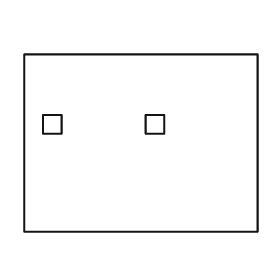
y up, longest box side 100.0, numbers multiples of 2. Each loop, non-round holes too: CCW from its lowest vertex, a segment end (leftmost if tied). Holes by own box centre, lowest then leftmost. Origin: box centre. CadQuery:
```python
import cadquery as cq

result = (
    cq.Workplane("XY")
    .moveTo(-50.0, -38.0)
    .lineTo(50.0, -38.0)
    .lineTo(50.0, 38.0)
    .lineTo(-50.0, 38.0)
    .close()
    .moveTo(-42.0, 4.0)
    .lineTo(-34.0, 4.0)
    .lineTo(-34.0, 12.0)
    .lineTo(-42.0, 12.0)
    .close()
    .moveTo(2.0, 4.0)
    .lineTo(10.0, 4.0)
    .lineTo(10.0, 12.0)
    .lineTo(2.0, 12.0)
    .close()
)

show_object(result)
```